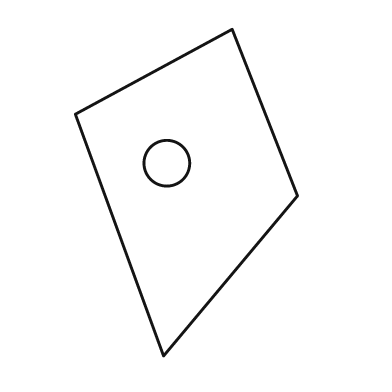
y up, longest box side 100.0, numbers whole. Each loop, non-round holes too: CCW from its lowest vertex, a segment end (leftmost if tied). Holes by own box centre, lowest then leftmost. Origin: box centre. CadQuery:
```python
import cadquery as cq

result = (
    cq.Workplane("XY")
    .moveTo(-7.0, -50.0)
    .lineTo(34.0, -1.0)
    .lineTo(14.0, 50.0)
    .lineTo(-34.0, 24.0)
    .close()
    .moveTo(-6.0, 9.0)
    .circle(7.0)
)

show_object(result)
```